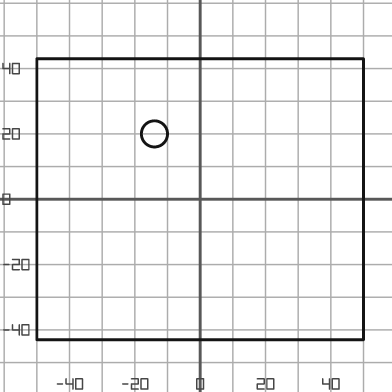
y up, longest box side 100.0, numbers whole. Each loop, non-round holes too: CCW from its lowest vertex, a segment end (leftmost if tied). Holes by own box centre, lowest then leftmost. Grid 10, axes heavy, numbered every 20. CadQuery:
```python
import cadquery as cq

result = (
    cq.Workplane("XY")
    .moveTo(-50.0, -43.0)
    .lineTo(50.0, -43.0)
    .lineTo(50.0, 43.0)
    .lineTo(-50.0, 43.0)
    .close()
    .moveTo(-14.0, 20.0)
    .circle(4.0)
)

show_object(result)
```